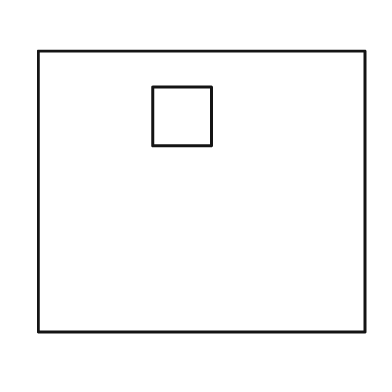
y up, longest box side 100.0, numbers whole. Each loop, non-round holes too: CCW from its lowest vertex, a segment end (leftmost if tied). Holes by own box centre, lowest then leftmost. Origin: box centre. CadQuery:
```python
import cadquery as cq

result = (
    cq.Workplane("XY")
    .moveTo(-50.0, -43.0)
    .lineTo(50.0, -43.0)
    .lineTo(50.0, 43.0)
    .lineTo(-50.0, 43.0)
    .close()
    .moveTo(-15.0, 14.0)
    .lineTo(3.0, 14.0)
    .lineTo(3.0, 32.0)
    .lineTo(-15.0, 32.0)
    .close()
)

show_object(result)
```